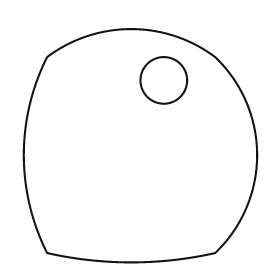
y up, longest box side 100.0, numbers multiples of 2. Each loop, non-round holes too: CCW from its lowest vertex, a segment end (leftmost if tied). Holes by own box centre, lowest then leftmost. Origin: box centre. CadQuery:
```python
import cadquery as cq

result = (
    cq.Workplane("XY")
    .moveTo(-40.0, -46.0)
    .threePointArc((-4.0, -50.0), (32.0, -46.0))
    .threePointArc((50.0, -4.0), (32.0, 38.0))
    .threePointArc((-4.0, 50.0), (-40.0, 38.0))
    .threePointArc((-50.0, -4.0), (-40.0, -46.0))
    .close()
    .moveTo(10.0, 28.0)
    .circle(10.0)
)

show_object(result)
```